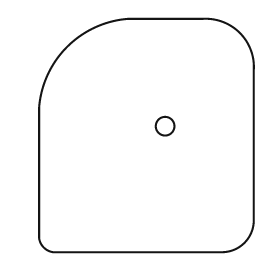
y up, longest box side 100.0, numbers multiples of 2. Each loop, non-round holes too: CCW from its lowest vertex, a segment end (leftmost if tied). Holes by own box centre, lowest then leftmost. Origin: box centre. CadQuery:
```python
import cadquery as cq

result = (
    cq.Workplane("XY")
    .moveTo(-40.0, -50.0)
    .lineTo(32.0, -50.0)
    .threePointArc((42.0, -46.0), (46.0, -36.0))
    .lineTo(46.0, 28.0)
    .threePointArc((40.0, 44.0), (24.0, 50.0))
    .lineTo(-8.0, 50.0)
    .threePointArc((-34.0, 38.0), (-46.0, 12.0))
    .lineTo(-46.0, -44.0)
    .threePointArc((-44.0, -48.0), (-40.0, -50.0))
    .close()
    .moveTo(8.0, 4.0)
    .circle(4.0)
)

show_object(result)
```